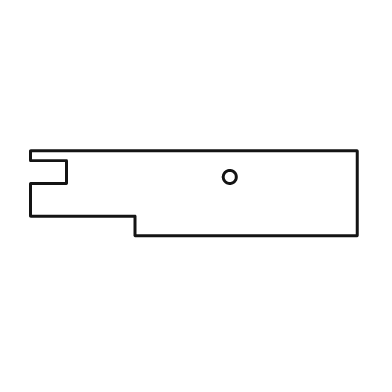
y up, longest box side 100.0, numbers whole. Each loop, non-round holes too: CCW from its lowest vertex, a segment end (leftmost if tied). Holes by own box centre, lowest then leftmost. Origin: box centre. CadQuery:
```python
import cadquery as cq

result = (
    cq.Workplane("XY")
    .moveTo(-18.0, -13.0)
    .lineTo(50.0, -13.0)
    .lineTo(50.0, 13.0)
    .lineTo(-50.0, 13.0)
    .lineTo(-50.0, 10.0)
    .lineTo(-39.0, 10.0)
    .lineTo(-39.0, 3.0)
    .lineTo(-50.0, 3.0)
    .lineTo(-50.0, -7.0)
    .lineTo(-18.0, -7.0)
    .close()
    .moveTo(11.0, 5.0)
    .circle(2.0)
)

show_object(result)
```